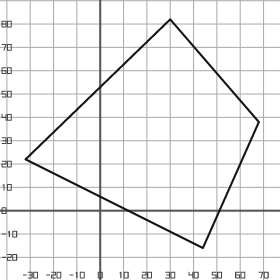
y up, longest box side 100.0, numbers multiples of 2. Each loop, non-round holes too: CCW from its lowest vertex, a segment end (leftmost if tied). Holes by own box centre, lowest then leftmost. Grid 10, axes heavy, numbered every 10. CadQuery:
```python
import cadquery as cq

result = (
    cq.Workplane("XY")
    .moveTo(44.0, -16.0)
    .lineTo(68.0, 38.0)
    .lineTo(30.0, 82.0)
    .lineTo(-32.0, 22.0)
    .close()
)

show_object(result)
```